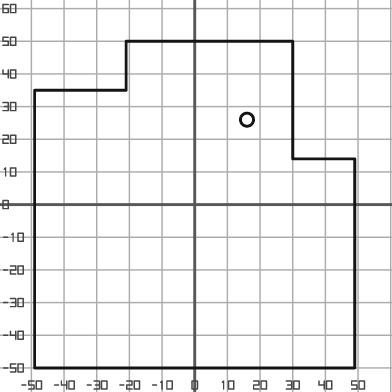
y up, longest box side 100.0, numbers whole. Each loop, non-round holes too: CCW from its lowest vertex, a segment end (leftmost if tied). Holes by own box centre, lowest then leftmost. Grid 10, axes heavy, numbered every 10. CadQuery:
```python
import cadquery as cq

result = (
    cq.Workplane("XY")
    .moveTo(-49.0, -50.0)
    .lineTo(49.0, -50.0)
    .lineTo(49.0, 14.0)
    .lineTo(30.0, 14.0)
    .lineTo(30.0, 50.0)
    .lineTo(-21.0, 50.0)
    .lineTo(-21.0, 35.0)
    .lineTo(-49.0, 35.0)
    .close()
    .moveTo(16.0, 26.0)
    .circle(2.0)
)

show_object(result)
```